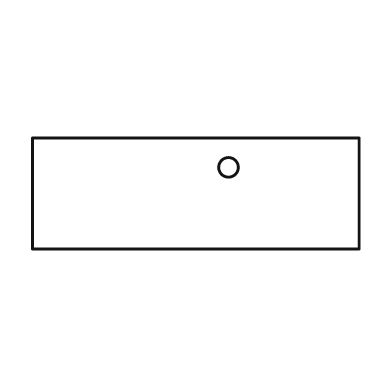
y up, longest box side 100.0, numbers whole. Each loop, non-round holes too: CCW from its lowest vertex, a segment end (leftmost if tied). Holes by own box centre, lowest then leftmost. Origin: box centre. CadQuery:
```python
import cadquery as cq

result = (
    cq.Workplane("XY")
    .moveTo(-50.0, -17.0)
    .lineTo(50.0, -17.0)
    .lineTo(50.0, 17.0)
    .lineTo(-50.0, 17.0)
    .close()
    .moveTo(10.0, 8.0)
    .circle(3.0)
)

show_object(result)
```